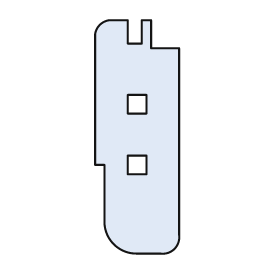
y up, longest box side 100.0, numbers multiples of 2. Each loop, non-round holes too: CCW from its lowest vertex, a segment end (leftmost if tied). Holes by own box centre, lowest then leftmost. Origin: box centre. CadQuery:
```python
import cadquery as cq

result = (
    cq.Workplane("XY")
    .moveTo(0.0, -50.0)
    .lineTo(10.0, -50.0)
    .threePointArc((16.0, -48.0), (18.0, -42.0))
    .lineTo(18.0, 38.0)
    .lineTo(6.0, 38.0)
    .lineTo(6.0, 50.0)
    .lineTo(2.0, 50.0)
    .lineTo(2.0, 40.0)
    .lineTo(-4.0, 40.0)
    .lineTo(-4.0, 50.0)
    .lineTo(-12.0, 50.0)
    .threePointArc((-16.0, 48.0), (-18.0, 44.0))
    .lineTo(-18.0, -12.0)
    .lineTo(-14.0, -12.0)
    .lineTo(-14.0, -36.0)
    .threePointArc((-10.0, -46.0), (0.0, -50.0))
    .close()
    .moveTo(-4.0, -16.0)
    .lineTo(4.0, -16.0)
    .lineTo(4.0, -8.0)
    .lineTo(-4.0, -8.0)
    .close()
    .moveTo(-4.0, 10.0)
    .lineTo(4.0, 10.0)
    .lineTo(4.0, 18.0)
    .lineTo(-4.0, 18.0)
    .close()
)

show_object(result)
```